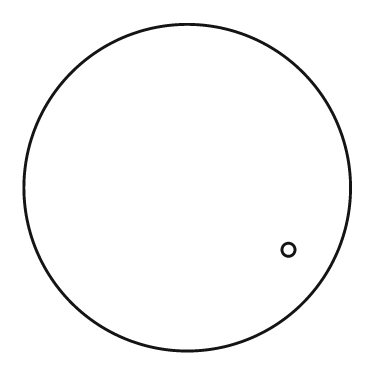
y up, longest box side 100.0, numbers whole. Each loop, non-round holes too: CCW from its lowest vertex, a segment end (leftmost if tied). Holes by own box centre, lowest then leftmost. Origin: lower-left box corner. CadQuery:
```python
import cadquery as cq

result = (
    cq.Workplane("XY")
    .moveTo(50.0, 50.0)
    .circle(50.0)
    .moveTo(81.0, 31.0)
    .circle(2.0)
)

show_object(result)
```